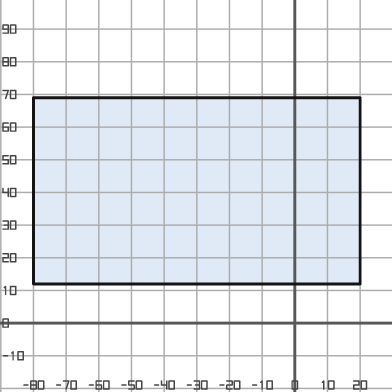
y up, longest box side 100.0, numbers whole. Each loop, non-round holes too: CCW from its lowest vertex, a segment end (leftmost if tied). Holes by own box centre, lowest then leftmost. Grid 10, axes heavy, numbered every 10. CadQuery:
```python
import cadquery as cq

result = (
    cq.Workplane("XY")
    .moveTo(-80.0, 12.0)
    .lineTo(20.0, 12.0)
    .lineTo(20.0, 69.0)
    .lineTo(-80.0, 69.0)
    .close()
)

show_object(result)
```